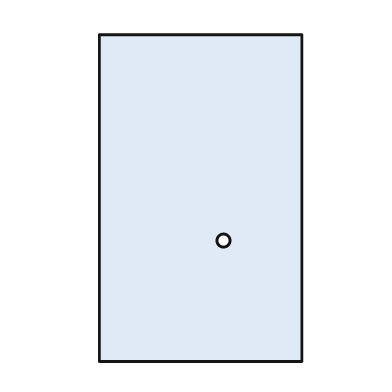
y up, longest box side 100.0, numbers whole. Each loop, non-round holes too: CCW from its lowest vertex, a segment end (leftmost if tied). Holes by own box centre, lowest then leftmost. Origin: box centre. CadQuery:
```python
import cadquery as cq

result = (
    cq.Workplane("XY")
    .moveTo(-31.0, -50.0)
    .lineTo(31.0, -50.0)
    .lineTo(31.0, 50.0)
    .lineTo(-31.0, 50.0)
    .close()
    .moveTo(7.0, -13.0)
    .circle(2.0)
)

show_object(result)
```